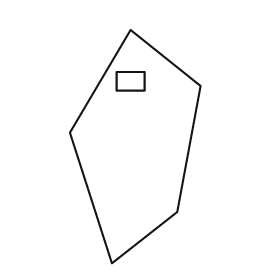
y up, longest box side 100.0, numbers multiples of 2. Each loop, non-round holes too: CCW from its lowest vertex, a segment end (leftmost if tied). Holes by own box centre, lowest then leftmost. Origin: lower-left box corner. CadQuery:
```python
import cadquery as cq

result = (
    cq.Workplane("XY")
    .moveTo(18.0, 0.0)
    .lineTo(46.0, 22.0)
    .lineTo(56.0, 76.0)
    .lineTo(26.0, 100.0)
    .lineTo(0.0, 56.0)
    .close()
    .moveTo(20.0, 74.0)
    .lineTo(32.0, 74.0)
    .lineTo(32.0, 82.0)
    .lineTo(20.0, 82.0)
    .close()
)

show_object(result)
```